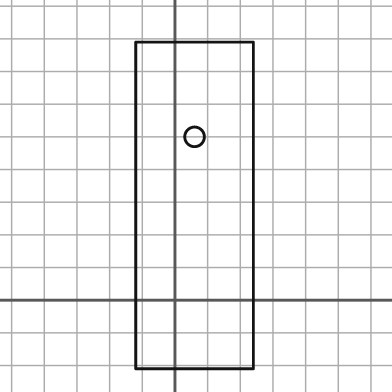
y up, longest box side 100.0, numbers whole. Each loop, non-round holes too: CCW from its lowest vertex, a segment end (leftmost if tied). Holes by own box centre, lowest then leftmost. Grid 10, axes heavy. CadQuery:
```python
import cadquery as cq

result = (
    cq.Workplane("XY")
    .moveTo(-12.0, -21.0)
    .lineTo(24.0, -21.0)
    .lineTo(24.0, 79.0)
    .lineTo(-12.0, 79.0)
    .close()
    .moveTo(6.0, 50.0)
    .circle(3.0)
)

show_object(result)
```